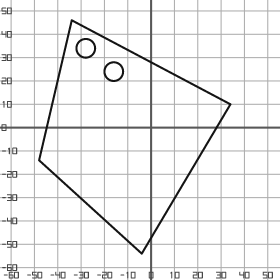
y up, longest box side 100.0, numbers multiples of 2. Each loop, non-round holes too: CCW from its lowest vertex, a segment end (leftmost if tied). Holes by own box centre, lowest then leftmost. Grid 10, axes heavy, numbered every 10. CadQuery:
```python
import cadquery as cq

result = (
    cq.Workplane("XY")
    .moveTo(-4.0, -54.0)
    .lineTo(34.0, 10.0)
    .lineTo(-34.0, 46.0)
    .lineTo(-48.0, -14.0)
    .close()
    .moveTo(-16.0, 24.0)
    .circle(4.0)
    .moveTo(-28.0, 34.0)
    .circle(4.0)
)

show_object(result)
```